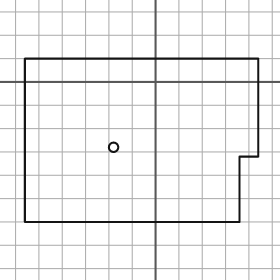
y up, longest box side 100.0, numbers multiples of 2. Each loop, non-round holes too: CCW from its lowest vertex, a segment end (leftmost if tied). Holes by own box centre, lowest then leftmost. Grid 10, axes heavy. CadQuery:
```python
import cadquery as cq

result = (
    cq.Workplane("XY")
    .moveTo(-56.0, -60.0)
    .lineTo(36.0, -60.0)
    .lineTo(36.0, -32.0)
    .lineTo(44.0, -32.0)
    .lineTo(44.0, 10.0)
    .lineTo(-56.0, 10.0)
    .close()
    .moveTo(-18.0, -28.0)
    .circle(2.0)
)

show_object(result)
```